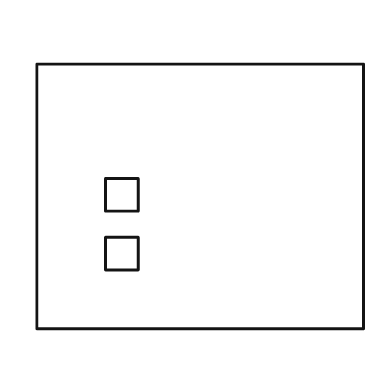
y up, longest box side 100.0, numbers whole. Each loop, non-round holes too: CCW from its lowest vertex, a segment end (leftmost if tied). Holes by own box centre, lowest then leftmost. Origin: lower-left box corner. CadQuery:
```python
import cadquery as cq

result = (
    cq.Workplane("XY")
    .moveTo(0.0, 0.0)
    .lineTo(100.0, 0.0)
    .lineTo(100.0, 81.0)
    .lineTo(0.0, 81.0)
    .close()
    .moveTo(21.0, 18.0)
    .lineTo(31.0, 18.0)
    .lineTo(31.0, 28.0)
    .lineTo(21.0, 28.0)
    .close()
    .moveTo(21.0, 36.0)
    .lineTo(31.0, 36.0)
    .lineTo(31.0, 46.0)
    .lineTo(21.0, 46.0)
    .close()
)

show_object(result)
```